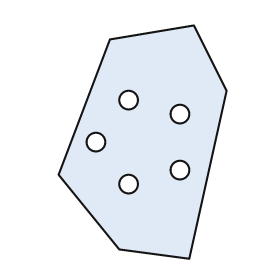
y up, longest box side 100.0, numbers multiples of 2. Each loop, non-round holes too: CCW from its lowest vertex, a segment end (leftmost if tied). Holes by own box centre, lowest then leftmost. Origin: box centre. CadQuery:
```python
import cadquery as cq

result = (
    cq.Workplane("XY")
    .moveTo(20.0, -50.0)
    .lineTo(36.0, 22.0)
    .lineTo(22.0, 50.0)
    .lineTo(-14.0, 44.0)
    .lineTo(-36.0, -14.0)
    .lineTo(-10.0, -46.0)
    .close()
    .moveTo(-6.0, -18.0)
    .circle(4.0)
    .moveTo(16.0, -12.0)
    .circle(4.0)
    .moveTo(-20.0, 0.0)
    .circle(4.0)
    .moveTo(16.0, 12.0)
    .circle(4.0)
    .moveTo(-6.0, 18.0)
    .circle(4.0)
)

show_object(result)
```